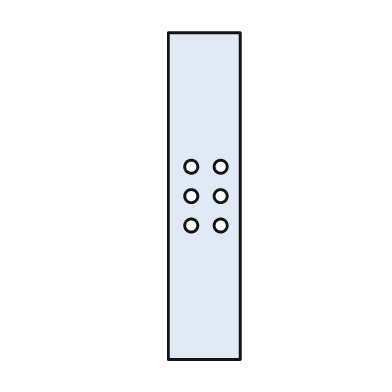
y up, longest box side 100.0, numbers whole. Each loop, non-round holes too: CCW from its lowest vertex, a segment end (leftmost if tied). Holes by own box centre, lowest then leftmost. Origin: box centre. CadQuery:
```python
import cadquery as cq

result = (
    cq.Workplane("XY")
    .moveTo(-11.0, -50.0)
    .lineTo(11.0, -50.0)
    .lineTo(11.0, 50.0)
    .lineTo(-11.0, 50.0)
    .close()
    .moveTo(-4.0, -9.0)
    .circle(2.0)
    .moveTo(5.0, -9.0)
    .circle(2.0)
    .moveTo(-4.0, 0.0)
    .circle(2.0)
    .moveTo(5.0, 0.0)
    .circle(2.0)
    .moveTo(-4.0, 9.0)
    .circle(2.0)
    .moveTo(5.0, 9.0)
    .circle(2.0)
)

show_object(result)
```